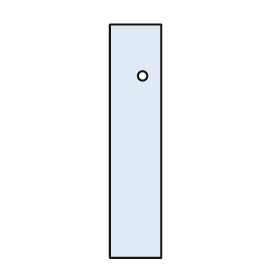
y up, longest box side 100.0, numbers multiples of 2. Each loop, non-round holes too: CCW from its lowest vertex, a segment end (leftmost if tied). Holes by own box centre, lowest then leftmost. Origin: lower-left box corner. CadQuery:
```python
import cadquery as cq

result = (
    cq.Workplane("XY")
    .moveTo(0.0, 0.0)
    .lineTo(22.0, 0.0)
    .lineTo(22.0, 100.0)
    .lineTo(0.0, 100.0)
    .close()
    .moveTo(14.0, 78.0)
    .circle(2.0)
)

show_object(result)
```